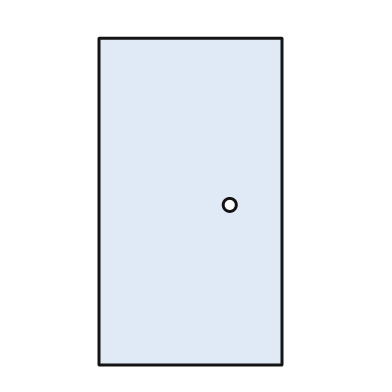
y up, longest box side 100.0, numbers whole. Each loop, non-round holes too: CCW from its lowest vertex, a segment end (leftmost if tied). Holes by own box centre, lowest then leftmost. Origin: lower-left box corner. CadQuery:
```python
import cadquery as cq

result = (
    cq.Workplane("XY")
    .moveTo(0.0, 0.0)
    .lineTo(56.0, 0.0)
    .lineTo(56.0, 100.0)
    .lineTo(0.0, 100.0)
    .close()
    .moveTo(40.0, 49.0)
    .circle(2.0)
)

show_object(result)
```